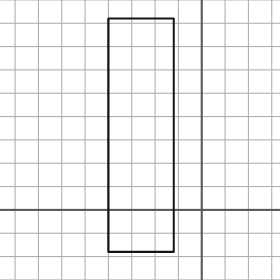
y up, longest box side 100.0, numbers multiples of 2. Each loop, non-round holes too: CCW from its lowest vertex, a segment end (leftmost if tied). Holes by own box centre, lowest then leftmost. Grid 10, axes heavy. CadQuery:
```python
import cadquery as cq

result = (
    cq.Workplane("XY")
    .moveTo(-40.0, -18.0)
    .lineTo(-12.0, -18.0)
    .lineTo(-12.0, 82.0)
    .lineTo(-40.0, 82.0)
    .close()
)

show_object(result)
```